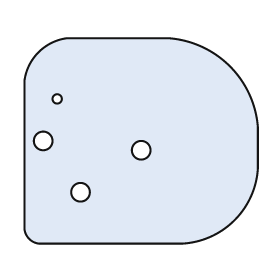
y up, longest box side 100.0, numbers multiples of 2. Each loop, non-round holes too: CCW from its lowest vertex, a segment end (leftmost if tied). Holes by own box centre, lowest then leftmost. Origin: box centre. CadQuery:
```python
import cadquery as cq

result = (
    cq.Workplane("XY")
    .moveTo(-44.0, -44.0)
    .lineTo(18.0, -44.0)
    .threePointArc((40.0, -34.0), (50.0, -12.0))
    .lineTo(50.0, 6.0)
    .threePointArc((38.0, 32.0), (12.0, 44.0))
    .lineTo(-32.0, 44.0)
    .threePointArc((-44.0, 38.0), (-50.0, 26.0))
    .lineTo(-50.0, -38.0)
    .threePointArc((-48.0, -42.0), (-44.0, -44.0))
    .close()
    .moveTo(-26.0, -22.0)
    .circle(4.0)
    .moveTo(0.0, -4.0)
    .circle(4.0)
    .moveTo(-42.0, 0.0)
    .circle(4.0)
    .moveTo(-36.0, 18.0)
    .circle(2.0)
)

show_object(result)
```